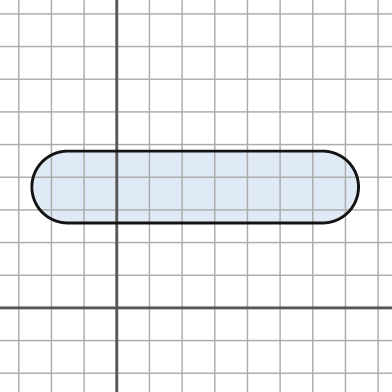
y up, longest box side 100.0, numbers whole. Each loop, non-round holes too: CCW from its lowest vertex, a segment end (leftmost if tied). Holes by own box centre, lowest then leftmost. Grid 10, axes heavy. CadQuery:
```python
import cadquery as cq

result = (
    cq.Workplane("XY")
    .moveTo(-15.0, 26.0)
    .lineTo(63.0, 26.0)
    .threePointArc((74.0, 37.0), (63.0, 48.0))
    .lineTo(-15.0, 48.0)
    .threePointArc((-26.0, 37.0), (-15.0, 26.0))
    .close()
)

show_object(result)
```